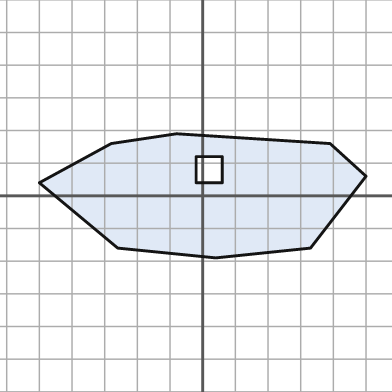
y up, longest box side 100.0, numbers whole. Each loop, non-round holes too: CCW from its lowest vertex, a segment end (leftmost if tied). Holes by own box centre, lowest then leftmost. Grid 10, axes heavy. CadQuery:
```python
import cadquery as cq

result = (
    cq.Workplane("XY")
    .moveTo(4.0, -19.0)
    .lineTo(33.0, -16.0)
    .lineTo(50.0, 6.0)
    .lineTo(39.0, 16.0)
    .lineTo(-8.0, 19.0)
    .lineTo(-28.0, 16.0)
    .lineTo(-50.0, 4.0)
    .lineTo(-26.0, -16.0)
    .close()
    .moveTo(-2.0, 4.0)
    .lineTo(6.0, 4.0)
    .lineTo(6.0, 12.0)
    .lineTo(-2.0, 12.0)
    .close()
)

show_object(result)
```